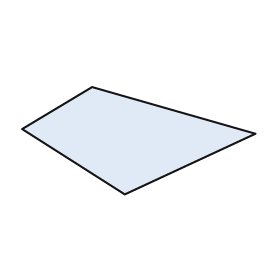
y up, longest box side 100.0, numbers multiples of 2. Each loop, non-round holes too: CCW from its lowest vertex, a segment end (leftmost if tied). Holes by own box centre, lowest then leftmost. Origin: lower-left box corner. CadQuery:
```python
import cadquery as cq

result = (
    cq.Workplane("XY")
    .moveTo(44.0, 0.0)
    .lineTo(100.0, 26.0)
    .lineTo(30.0, 46.0)
    .lineTo(0.0, 28.0)
    .close()
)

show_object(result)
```